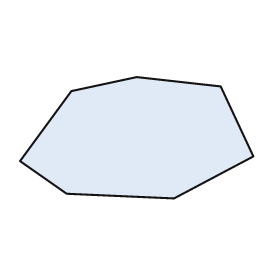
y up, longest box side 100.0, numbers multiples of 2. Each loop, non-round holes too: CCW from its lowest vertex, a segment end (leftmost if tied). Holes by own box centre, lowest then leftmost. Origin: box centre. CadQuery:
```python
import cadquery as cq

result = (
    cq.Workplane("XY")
    .moveTo(16.0, -26.0)
    .lineTo(50.0, -8.0)
    .lineTo(36.0, 22.0)
    .lineTo(0.0, 26.0)
    .lineTo(-28.0, 20.0)
    .lineTo(-50.0, -10.0)
    .lineTo(-30.0, -24.0)
    .close()
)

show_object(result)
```